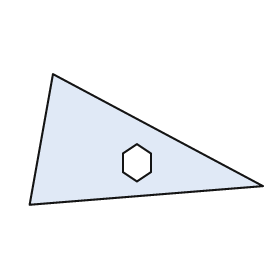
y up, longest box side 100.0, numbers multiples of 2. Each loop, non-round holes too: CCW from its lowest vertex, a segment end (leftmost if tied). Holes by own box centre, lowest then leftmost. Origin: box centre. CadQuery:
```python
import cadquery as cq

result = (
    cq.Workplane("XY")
    .moveTo(-50.0, -28.0)
    .lineTo(50.0, -20.0)
    .lineTo(-40.0, 28.0)
    .close()
    .moveTo(-4.0, -18.0)
    .lineTo(2.0, -14.0)
    .lineTo(2.0, -6.0)
    .lineTo(-4.0, -2.0)
    .lineTo(-10.0, -6.0)
    .lineTo(-10.0, -14.0)
    .close()
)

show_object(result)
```